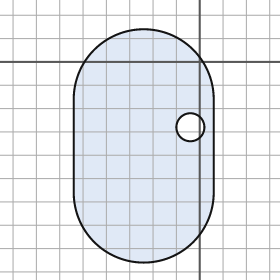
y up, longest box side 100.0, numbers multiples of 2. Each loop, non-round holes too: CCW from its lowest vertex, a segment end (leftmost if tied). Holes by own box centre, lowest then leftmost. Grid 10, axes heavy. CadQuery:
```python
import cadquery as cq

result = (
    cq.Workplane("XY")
    .moveTo(-54.0, -56.0)
    .threePointArc((-24.0, -86.0), (6.0, -56.0))
    .lineTo(6.0, -16.0)
    .threePointArc((-24.0, 14.0), (-54.0, -16.0))
    .close()
    .moveTo(-4.0, -28.0)
    .circle(6.0)
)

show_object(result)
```